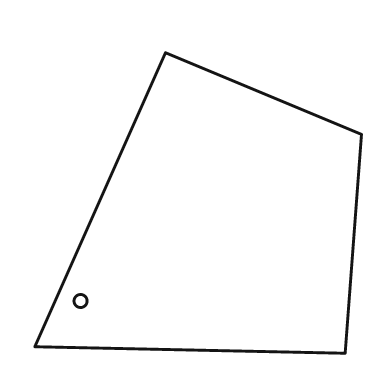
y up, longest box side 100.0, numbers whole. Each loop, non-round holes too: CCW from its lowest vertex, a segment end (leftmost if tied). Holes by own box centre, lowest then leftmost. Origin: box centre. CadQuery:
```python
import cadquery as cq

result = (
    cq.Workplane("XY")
    .moveTo(45.0, -46.0)
    .lineTo(50.0, 21.0)
    .lineTo(-10.0, 46.0)
    .lineTo(-50.0, -44.0)
    .close()
    .moveTo(-36.0, -30.0)
    .circle(2.0)
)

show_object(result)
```